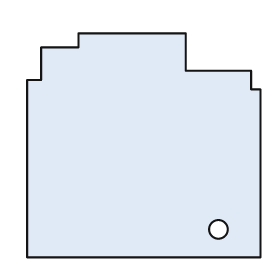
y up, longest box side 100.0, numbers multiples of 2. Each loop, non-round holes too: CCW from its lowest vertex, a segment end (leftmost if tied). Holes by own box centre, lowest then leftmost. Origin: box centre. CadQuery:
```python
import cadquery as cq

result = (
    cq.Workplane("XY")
    .moveTo(-50.0, -48.0)
    .lineTo(50.0, -48.0)
    .lineTo(50.0, 24.0)
    .lineTo(46.0, 24.0)
    .lineTo(46.0, 32.0)
    .lineTo(18.0, 32.0)
    .lineTo(18.0, 48.0)
    .lineTo(-28.0, 48.0)
    .lineTo(-28.0, 42.0)
    .lineTo(-44.0, 42.0)
    .lineTo(-44.0, 28.0)
    .lineTo(-50.0, 28.0)
    .close()
    .moveTo(32.0, -36.0)
    .circle(4.0)
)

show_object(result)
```